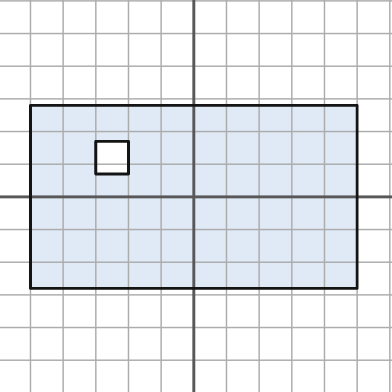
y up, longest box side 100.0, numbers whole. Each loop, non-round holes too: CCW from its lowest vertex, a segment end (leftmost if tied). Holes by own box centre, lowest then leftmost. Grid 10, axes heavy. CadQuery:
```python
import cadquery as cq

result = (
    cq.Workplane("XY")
    .moveTo(-50.0, -28.0)
    .lineTo(50.0, -28.0)
    .lineTo(50.0, 28.0)
    .lineTo(-50.0, 28.0)
    .close()
    .moveTo(-30.0, 7.0)
    .lineTo(-20.0, 7.0)
    .lineTo(-20.0, 17.0)
    .lineTo(-30.0, 17.0)
    .close()
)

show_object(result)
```